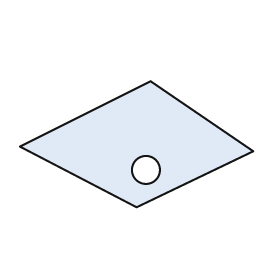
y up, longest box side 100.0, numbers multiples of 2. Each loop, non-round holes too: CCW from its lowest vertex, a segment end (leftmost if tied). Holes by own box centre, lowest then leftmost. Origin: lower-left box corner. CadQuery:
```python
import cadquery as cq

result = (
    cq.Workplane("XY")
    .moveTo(50.0, 0.0)
    .lineTo(100.0, 24.0)
    .lineTo(56.0, 54.0)
    .lineTo(0.0, 26.0)
    .close()
    .moveTo(54.0, 16.0)
    .circle(6.0)
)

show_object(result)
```